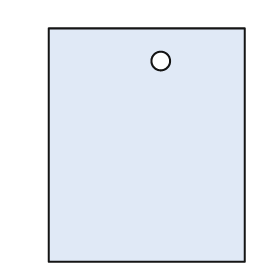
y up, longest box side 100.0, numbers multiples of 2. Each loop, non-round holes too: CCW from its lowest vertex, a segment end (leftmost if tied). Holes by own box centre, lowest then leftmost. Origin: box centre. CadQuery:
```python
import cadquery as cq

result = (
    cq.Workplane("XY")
    .moveTo(-42.0, -50.0)
    .lineTo(42.0, -50.0)
    .lineTo(42.0, 50.0)
    .lineTo(-42.0, 50.0)
    .close()
    .moveTo(6.0, 36.0)
    .circle(4.0)
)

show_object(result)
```